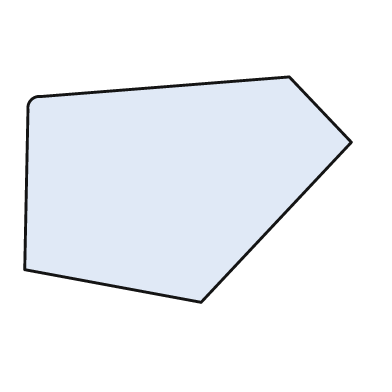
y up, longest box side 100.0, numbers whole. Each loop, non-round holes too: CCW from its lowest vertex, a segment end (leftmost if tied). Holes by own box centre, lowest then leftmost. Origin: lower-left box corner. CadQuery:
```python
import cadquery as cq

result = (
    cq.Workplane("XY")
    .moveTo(54.0, 0.0)
    .lineTo(100.0, 49.0)
    .lineTo(81.0, 69.0)
    .lineTo(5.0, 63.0)
    .threePointArc((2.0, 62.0), (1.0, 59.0))
    .lineTo(0.0, 10.0)
    .close()
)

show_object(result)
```